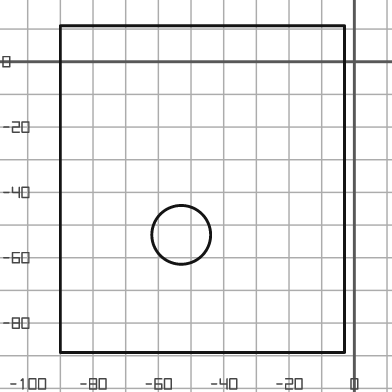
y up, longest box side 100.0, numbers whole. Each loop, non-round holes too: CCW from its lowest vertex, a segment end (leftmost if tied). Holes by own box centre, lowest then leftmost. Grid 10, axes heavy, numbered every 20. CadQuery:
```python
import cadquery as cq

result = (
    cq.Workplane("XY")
    .moveTo(-90.0, -89.0)
    .lineTo(-3.0, -89.0)
    .lineTo(-3.0, 11.0)
    .lineTo(-90.0, 11.0)
    .close()
    .moveTo(-53.0, -53.0)
    .circle(9.0)
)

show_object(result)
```